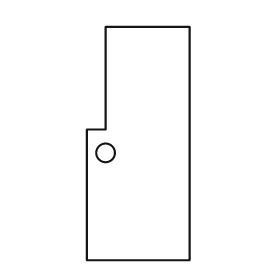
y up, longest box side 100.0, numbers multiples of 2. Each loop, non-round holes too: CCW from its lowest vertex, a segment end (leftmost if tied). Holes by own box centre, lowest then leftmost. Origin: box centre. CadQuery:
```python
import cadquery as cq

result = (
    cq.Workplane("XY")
    .moveTo(-22.0, -50.0)
    .lineTo(22.0, -50.0)
    .lineTo(22.0, 50.0)
    .lineTo(-14.0, 50.0)
    .lineTo(-14.0, 6.0)
    .lineTo(-22.0, 6.0)
    .close()
    .moveTo(-14.0, -4.0)
    .circle(4.0)
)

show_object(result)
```